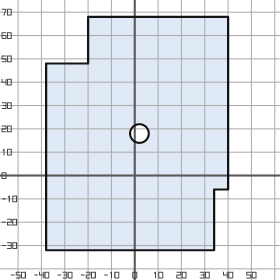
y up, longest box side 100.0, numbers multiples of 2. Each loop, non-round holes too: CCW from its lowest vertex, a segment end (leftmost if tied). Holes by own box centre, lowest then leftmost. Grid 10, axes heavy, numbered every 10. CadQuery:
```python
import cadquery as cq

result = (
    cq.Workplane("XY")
    .moveTo(-38.0, -32.0)
    .lineTo(34.0, -32.0)
    .lineTo(34.0, -6.0)
    .lineTo(40.0, -6.0)
    .lineTo(40.0, 68.0)
    .lineTo(-20.0, 68.0)
    .lineTo(-20.0, 48.0)
    .lineTo(-38.0, 48.0)
    .close()
    .moveTo(2.0, 18.0)
    .circle(4.0)
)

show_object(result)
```